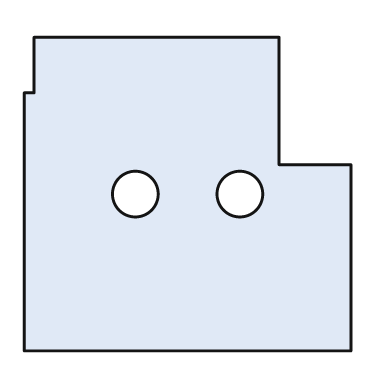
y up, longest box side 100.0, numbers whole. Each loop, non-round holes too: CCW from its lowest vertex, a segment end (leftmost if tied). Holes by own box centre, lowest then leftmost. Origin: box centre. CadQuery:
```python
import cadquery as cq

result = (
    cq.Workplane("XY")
    .moveTo(-50.0, -48.0)
    .lineTo(50.0, -48.0)
    .lineTo(50.0, 9.0)
    .lineTo(28.0, 9.0)
    .lineTo(28.0, 48.0)
    .lineTo(-47.0, 48.0)
    .lineTo(-47.0, 31.0)
    .lineTo(-50.0, 31.0)
    .close()
    .moveTo(-16.0, 0.0)
    .circle(7.0)
    .moveTo(16.0, 0.0)
    .circle(7.0)
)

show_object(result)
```